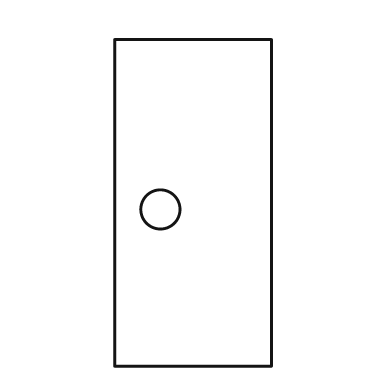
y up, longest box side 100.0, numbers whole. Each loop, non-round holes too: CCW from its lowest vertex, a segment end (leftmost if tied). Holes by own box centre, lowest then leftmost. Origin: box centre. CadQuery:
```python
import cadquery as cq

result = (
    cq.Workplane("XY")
    .moveTo(-24.0, -50.0)
    .lineTo(24.0, -50.0)
    .lineTo(24.0, 50.0)
    .lineTo(-24.0, 50.0)
    .close()
    .moveTo(-10.0, -2.0)
    .circle(6.0)
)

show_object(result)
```